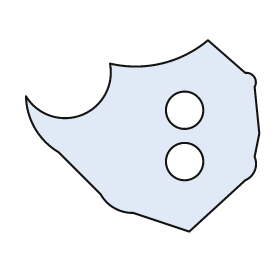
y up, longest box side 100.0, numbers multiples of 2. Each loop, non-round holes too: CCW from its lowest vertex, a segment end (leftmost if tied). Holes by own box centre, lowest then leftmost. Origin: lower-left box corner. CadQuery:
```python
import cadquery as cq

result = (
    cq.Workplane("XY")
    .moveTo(70.0, 0.0)
    .lineTo(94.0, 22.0)
    .threePointArc((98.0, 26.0), (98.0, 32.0))
    .lineTo(100.0, 42.0)
    .lineTo(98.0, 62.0)
    .threePointArc((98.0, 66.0), (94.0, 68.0))
    .lineTo(78.0, 82.0)
    .threePointArc((58.0, 72.0), (36.0, 72.0))
    .threePointArc((24.0, 50.0), (0.0, 58.0))
    .threePointArc((4.0, 44.0), (14.0, 34.0))
    .lineTo(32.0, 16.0)
    .threePointArc((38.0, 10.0), (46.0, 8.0))
    .close()
    .moveTo(68.0, 30.0)
    .circle(8.0)
    .moveTo(68.0, 52.0)
    .circle(8.0)
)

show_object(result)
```